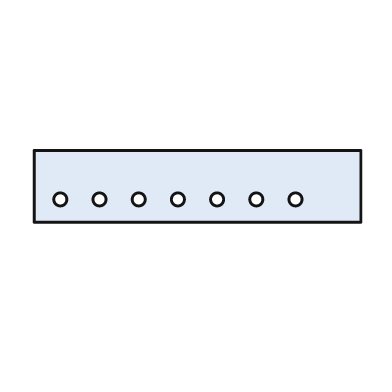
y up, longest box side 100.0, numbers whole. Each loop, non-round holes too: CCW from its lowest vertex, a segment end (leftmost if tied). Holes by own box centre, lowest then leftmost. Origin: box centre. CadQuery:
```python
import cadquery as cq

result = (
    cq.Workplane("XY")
    .moveTo(-50.0, -11.0)
    .lineTo(50.0, -11.0)
    .lineTo(50.0, 11.0)
    .lineTo(-50.0, 11.0)
    .close()
    .moveTo(-42.0, -4.0)
    .circle(2.0)
    .moveTo(-30.0, -4.0)
    .circle(2.0)
    .moveTo(-18.0, -4.0)
    .circle(2.0)
    .moveTo(-6.0, -4.0)
    .circle(2.0)
    .moveTo(6.0, -4.0)
    .circle(2.0)
    .moveTo(18.0, -4.0)
    .circle(2.0)
    .moveTo(30.0, -4.0)
    .circle(2.0)
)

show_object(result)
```